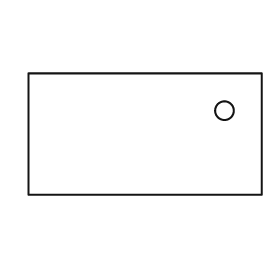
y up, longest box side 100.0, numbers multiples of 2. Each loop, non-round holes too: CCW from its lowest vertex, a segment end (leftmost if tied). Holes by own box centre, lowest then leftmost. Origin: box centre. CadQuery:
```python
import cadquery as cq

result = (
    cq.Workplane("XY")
    .moveTo(-50.0, -26.0)
    .lineTo(50.0, -26.0)
    .lineTo(50.0, 26.0)
    .lineTo(-50.0, 26.0)
    .close()
    .moveTo(34.0, 10.0)
    .circle(4.0)
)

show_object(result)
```